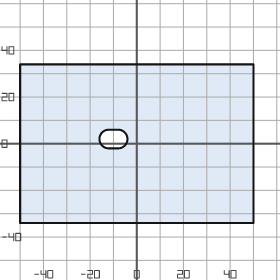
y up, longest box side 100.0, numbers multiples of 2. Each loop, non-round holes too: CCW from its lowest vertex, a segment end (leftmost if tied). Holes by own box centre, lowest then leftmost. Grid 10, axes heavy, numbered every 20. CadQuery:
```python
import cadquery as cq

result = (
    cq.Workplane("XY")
    .moveTo(-50.0, -34.0)
    .lineTo(50.0, -34.0)
    .lineTo(50.0, 34.0)
    .lineTo(-50.0, 34.0)
    .close()
    .moveTo(-12.0, -2.0)
    .lineTo(-8.0, -2.0)
    .threePointArc((-4.0, 2.0), (-8.0, 6.0))
    .lineTo(-12.0, 6.0)
    .threePointArc((-16.0, 2.0), (-12.0, -2.0))
    .close()
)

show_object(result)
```